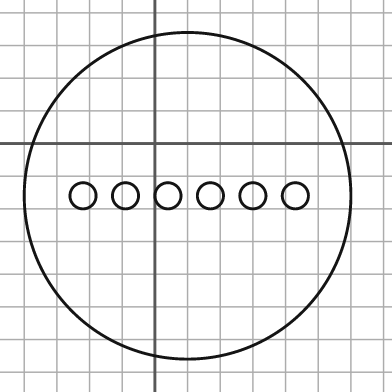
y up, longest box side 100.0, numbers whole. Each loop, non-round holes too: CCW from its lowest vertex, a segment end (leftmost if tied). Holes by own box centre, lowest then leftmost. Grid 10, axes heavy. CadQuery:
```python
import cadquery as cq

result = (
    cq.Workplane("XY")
    .moveTo(10.0, -16.0)
    .circle(50.0)
    .moveTo(-22.0, -16.0)
    .circle(4.0)
    .moveTo(-9.0, -16.0)
    .circle(4.0)
    .moveTo(4.0, -16.0)
    .circle(4.0)
    .moveTo(17.0, -16.0)
    .circle(4.0)
    .moveTo(30.0, -16.0)
    .circle(4.0)
    .moveTo(43.0, -16.0)
    .circle(4.0)
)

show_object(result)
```